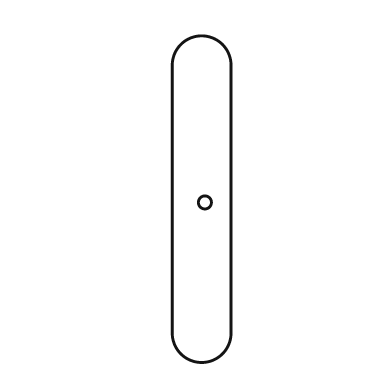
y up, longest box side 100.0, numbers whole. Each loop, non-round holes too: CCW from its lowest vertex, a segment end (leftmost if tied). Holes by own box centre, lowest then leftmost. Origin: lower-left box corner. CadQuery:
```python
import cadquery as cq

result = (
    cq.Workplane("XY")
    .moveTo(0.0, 9.0)
    .threePointArc((9.0, 0.0), (18.0, 9.0))
    .lineTo(18.0, 91.0)
    .threePointArc((9.0, 100.0), (0.0, 91.0))
    .close()
    .moveTo(10.0, 49.0)
    .circle(2.0)
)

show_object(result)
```